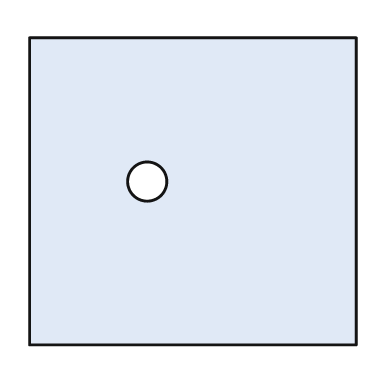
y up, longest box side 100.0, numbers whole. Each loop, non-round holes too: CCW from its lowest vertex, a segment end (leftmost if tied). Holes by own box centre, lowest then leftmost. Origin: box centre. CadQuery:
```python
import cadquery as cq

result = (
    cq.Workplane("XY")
    .moveTo(-50.0, -47.0)
    .lineTo(50.0, -47.0)
    .lineTo(50.0, 47.0)
    .lineTo(-50.0, 47.0)
    .close()
    .moveTo(-14.0, 3.0)
    .circle(6.0)
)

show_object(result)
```